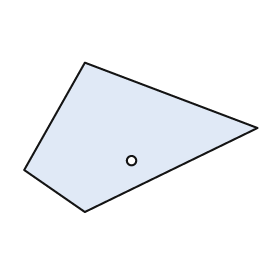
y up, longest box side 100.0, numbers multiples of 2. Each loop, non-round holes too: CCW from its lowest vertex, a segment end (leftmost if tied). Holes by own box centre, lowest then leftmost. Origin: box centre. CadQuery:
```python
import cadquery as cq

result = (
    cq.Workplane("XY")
    .moveTo(-24.0, -32.0)
    .lineTo(50.0, 4.0)
    .lineTo(-24.0, 32.0)
    .lineTo(-50.0, -14.0)
    .close()
    .moveTo(-4.0, -10.0)
    .circle(2.0)
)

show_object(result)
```